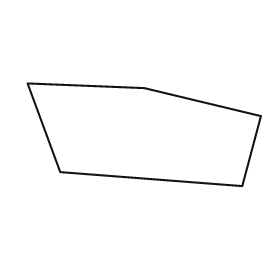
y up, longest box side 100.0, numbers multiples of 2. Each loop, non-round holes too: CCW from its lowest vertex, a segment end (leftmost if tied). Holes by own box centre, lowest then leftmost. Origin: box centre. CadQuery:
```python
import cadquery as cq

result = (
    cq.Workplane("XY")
    .moveTo(42.0, -22.0)
    .lineTo(50.0, 8.0)
    .lineTo(0.0, 20.0)
    .lineTo(-50.0, 22.0)
    .lineTo(-36.0, -16.0)
    .close()
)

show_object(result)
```